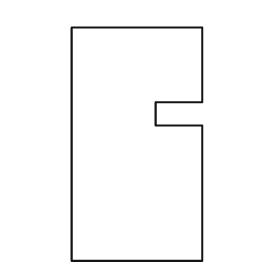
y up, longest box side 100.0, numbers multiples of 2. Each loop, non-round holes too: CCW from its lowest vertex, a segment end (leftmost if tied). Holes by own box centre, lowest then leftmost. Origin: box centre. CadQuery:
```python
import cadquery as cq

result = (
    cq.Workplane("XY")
    .moveTo(-28.0, -50.0)
    .lineTo(28.0, -50.0)
    .lineTo(28.0, 8.0)
    .lineTo(8.0, 8.0)
    .lineTo(8.0, 18.0)
    .lineTo(28.0, 18.0)
    .lineTo(28.0, 50.0)
    .lineTo(-28.0, 50.0)
    .close()
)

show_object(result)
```